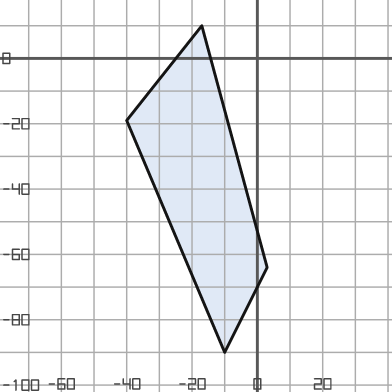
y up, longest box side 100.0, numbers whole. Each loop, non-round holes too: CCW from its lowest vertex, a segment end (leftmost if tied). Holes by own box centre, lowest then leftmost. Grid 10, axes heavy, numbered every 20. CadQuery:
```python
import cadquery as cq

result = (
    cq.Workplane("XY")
    .moveTo(-10.0, -90.0)
    .lineTo(3.0, -64.0)
    .lineTo(-17.0, 10.0)
    .lineTo(-40.0, -19.0)
    .close()
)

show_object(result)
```